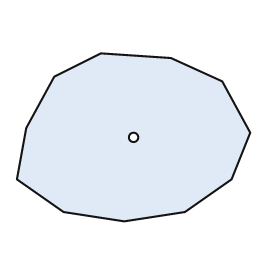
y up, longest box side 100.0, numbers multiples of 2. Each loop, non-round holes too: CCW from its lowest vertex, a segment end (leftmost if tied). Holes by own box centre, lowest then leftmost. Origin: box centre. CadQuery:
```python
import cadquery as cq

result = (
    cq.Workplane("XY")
    .moveTo(-4.0, -36.0)
    .lineTo(22.0, -32.0)
    .lineTo(42.0, -18.0)
    .lineTo(50.0, 2.0)
    .lineTo(38.0, 24.0)
    .lineTo(16.0, 34.0)
    .lineTo(-14.0, 36.0)
    .lineTo(-34.0, 26.0)
    .lineTo(-46.0, 4.0)
    .lineTo(-50.0, -18.0)
    .lineTo(-30.0, -32.0)
    .close()
    .moveTo(0.0, 0.0)
    .circle(2.0)
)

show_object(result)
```